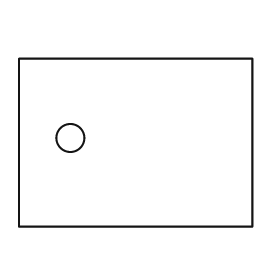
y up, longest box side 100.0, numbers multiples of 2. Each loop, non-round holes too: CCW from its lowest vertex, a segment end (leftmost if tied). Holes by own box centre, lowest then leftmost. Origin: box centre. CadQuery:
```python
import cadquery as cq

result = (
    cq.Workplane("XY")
    .moveTo(-50.0, -36.0)
    .lineTo(50.0, -36.0)
    .lineTo(50.0, 36.0)
    .lineTo(-50.0, 36.0)
    .close()
    .moveTo(-28.0, 2.0)
    .circle(6.0)
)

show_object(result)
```